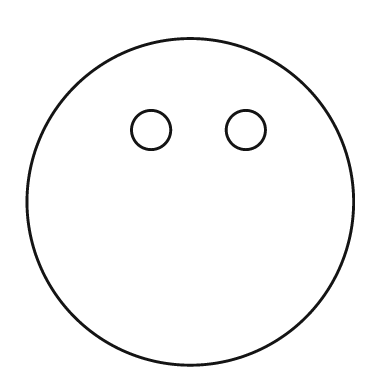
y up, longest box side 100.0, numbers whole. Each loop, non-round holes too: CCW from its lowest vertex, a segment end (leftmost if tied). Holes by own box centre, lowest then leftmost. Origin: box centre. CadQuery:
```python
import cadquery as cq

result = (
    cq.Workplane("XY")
    .moveTo(0.0, 0.0)
    .circle(50.0)
    .moveTo(-12.0, 22.0)
    .circle(6.0)
    .moveTo(17.0, 22.0)
    .circle(6.0)
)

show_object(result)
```